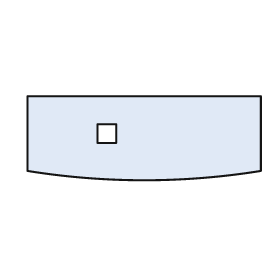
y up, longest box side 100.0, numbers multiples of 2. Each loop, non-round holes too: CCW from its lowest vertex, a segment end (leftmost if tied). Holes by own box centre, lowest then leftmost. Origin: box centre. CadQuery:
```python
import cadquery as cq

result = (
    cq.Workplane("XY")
    .moveTo(-50.0, -14.0)
    .threePointArc((0.0, -18.0), (50.0, -14.0))
    .lineTo(50.0, 18.0)
    .lineTo(-50.0, 18.0)
    .close()
    .moveTo(-20.0, -2.0)
    .lineTo(-12.0, -2.0)
    .lineTo(-12.0, 6.0)
    .lineTo(-20.0, 6.0)
    .close()
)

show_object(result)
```